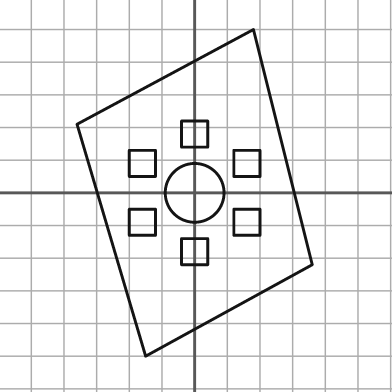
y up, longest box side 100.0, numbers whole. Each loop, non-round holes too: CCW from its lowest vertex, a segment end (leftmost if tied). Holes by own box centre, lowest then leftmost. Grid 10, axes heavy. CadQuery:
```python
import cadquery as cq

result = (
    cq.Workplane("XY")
    .moveTo(-15.0, -50.0)
    .lineTo(36.0, -22.0)
    .lineTo(18.0, 50.0)
    .lineTo(-36.0, 21.0)
    .close()
    .moveTo(-4.0, -22.0)
    .lineTo(4.0, -22.0)
    .lineTo(4.0, -14.0)
    .lineTo(-4.0, -14.0)
    .close()
    .moveTo(-20.0, -13.0)
    .lineTo(-12.0, -13.0)
    .lineTo(-12.0, -5.0)
    .lineTo(-20.0, -5.0)
    .close()
    .moveTo(12.0, -13.0)
    .lineTo(20.0, -13.0)
    .lineTo(20.0, -5.0)
    .lineTo(12.0, -5.0)
    .close()
    .moveTo(0.0, 0.0)
    .circle(9.0)
    .moveTo(-20.0, 5.0)
    .lineTo(-12.0, 5.0)
    .lineTo(-12.0, 13.0)
    .lineTo(-20.0, 13.0)
    .close()
    .moveTo(12.0, 5.0)
    .lineTo(20.0, 5.0)
    .lineTo(20.0, 13.0)
    .lineTo(12.0, 13.0)
    .close()
    .moveTo(-4.0, 14.0)
    .lineTo(4.0, 14.0)
    .lineTo(4.0, 22.0)
    .lineTo(-4.0, 22.0)
    .close()
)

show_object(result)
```